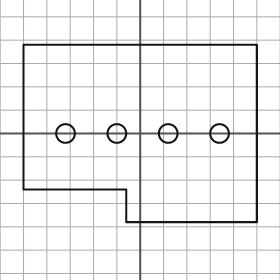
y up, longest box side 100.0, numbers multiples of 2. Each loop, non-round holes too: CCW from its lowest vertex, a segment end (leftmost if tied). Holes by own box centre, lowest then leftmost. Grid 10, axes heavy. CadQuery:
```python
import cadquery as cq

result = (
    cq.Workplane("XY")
    .moveTo(-6.0, -38.0)
    .lineTo(50.0, -38.0)
    .lineTo(50.0, 38.0)
    .lineTo(-50.0, 38.0)
    .lineTo(-50.0, -24.0)
    .lineTo(-6.0, -24.0)
    .close()
    .moveTo(-32.0, 0.0)
    .circle(4.0)
    .moveTo(-10.0, 0.0)
    .circle(4.0)
    .moveTo(12.0, 0.0)
    .circle(4.0)
    .moveTo(34.0, 0.0)
    .circle(4.0)
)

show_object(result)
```